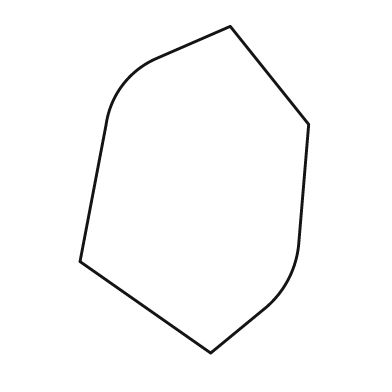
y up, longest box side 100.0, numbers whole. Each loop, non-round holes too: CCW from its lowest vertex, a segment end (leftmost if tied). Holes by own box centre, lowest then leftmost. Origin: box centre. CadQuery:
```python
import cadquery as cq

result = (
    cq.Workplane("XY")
    .moveTo(5.0, -50.0)
    .lineTo(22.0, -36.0)
    .threePointArc((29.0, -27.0), (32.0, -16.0))
    .lineTo(35.0, 20.0)
    .lineTo(11.0, 50.0)
    .lineTo(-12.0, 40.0)
    .threePointArc((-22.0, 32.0), (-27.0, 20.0))
    .lineTo(-35.0, -22.0)
    .close()
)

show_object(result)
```